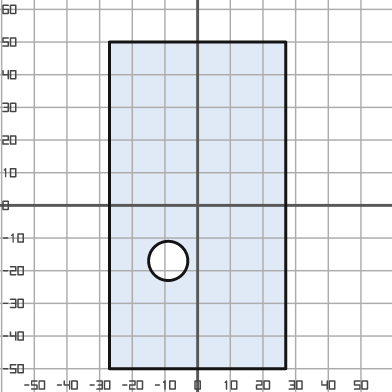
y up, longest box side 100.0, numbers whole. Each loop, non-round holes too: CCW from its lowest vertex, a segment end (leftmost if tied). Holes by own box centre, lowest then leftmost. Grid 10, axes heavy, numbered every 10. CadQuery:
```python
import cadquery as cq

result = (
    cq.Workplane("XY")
    .moveTo(-27.0, -50.0)
    .lineTo(27.0, -50.0)
    .lineTo(27.0, 50.0)
    .lineTo(-27.0, 50.0)
    .close()
    .moveTo(-9.0, -17.0)
    .circle(6.0)
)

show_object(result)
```